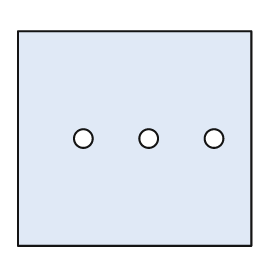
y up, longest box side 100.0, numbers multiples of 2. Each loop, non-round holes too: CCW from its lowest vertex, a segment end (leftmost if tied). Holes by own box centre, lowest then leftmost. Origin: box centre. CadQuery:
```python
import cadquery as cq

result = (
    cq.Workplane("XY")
    .moveTo(-50.0, -46.0)
    .lineTo(50.0, -46.0)
    .lineTo(50.0, 46.0)
    .lineTo(-50.0, 46.0)
    .close()
    .moveTo(-22.0, 0.0)
    .circle(4.0)
    .moveTo(6.0, 0.0)
    .circle(4.0)
    .moveTo(34.0, 0.0)
    .circle(4.0)
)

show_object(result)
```